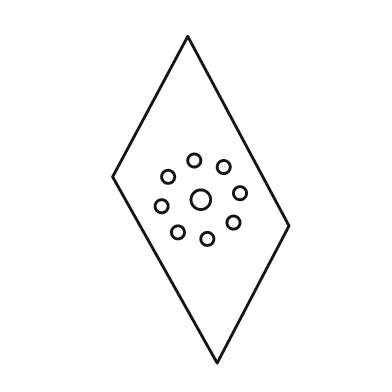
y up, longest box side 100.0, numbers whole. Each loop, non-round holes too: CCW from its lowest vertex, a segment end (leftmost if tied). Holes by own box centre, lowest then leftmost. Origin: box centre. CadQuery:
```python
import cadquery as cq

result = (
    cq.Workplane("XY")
    .moveTo(5.0, -50.0)
    .lineTo(27.0, -8.0)
    .lineTo(-4.0, 50.0)
    .lineTo(-27.0, 7.0)
    .close()
    .moveTo(2.0, -12.0)
    .circle(2.0)
    .moveTo(-7.0, -10.0)
    .circle(2.0)
    .moveTo(10.0, -7.0)
    .circle(2.0)
    .moveTo(-12.0, -2.0)
    .circle(2.0)
    .moveTo(0.0, 0.0)
    .circle(3.0)
    .moveTo(12.0, 2.0)
    .circle(2.0)
    .moveTo(-10.0, 7.0)
    .circle(2.0)
    .moveTo(7.0, 10.0)
    .circle(2.0)
    .moveTo(-2.0, 12.0)
    .circle(2.0)
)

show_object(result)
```